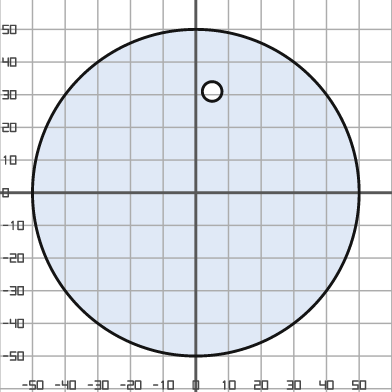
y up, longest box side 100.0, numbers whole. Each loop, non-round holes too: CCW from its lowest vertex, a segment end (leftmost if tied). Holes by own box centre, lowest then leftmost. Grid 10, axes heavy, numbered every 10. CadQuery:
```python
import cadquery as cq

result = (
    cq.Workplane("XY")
    .moveTo(0.0, 0.0)
    .circle(50.0)
    .moveTo(5.0, 31.0)
    .circle(3.0)
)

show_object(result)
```